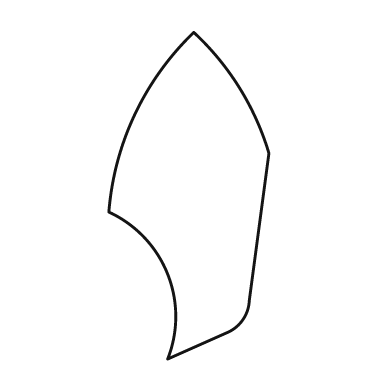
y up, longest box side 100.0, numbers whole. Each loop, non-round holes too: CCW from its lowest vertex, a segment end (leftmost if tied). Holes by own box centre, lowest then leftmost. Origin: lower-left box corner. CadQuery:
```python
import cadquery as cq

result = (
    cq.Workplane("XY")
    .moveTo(18.0, 0.0)
    .lineTo(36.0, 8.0)
    .threePointArc((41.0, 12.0), (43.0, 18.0))
    .lineTo(49.0, 63.0)
    .threePointArc((40.0, 83.0), (26.0, 100.0))
    .threePointArc((8.0, 75.0), (0.0, 45.0))
    .threePointArc((18.0, 26.0), (18.0, 0.0))
    .close()
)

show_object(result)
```